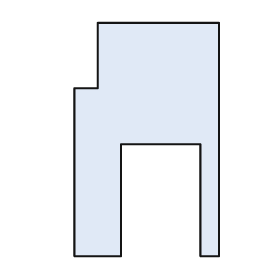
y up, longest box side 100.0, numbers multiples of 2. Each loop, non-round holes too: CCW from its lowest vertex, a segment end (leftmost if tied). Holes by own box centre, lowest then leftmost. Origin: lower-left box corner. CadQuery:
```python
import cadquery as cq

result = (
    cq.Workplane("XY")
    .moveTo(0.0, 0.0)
    .lineTo(20.0, 0.0)
    .lineTo(20.0, 48.0)
    .lineTo(54.0, 48.0)
    .lineTo(54.0, 0.0)
    .lineTo(62.0, 0.0)
    .lineTo(62.0, 100.0)
    .lineTo(10.0, 100.0)
    .lineTo(10.0, 72.0)
    .lineTo(0.0, 72.0)
    .close()
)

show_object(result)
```